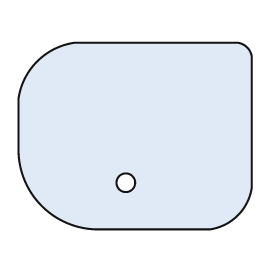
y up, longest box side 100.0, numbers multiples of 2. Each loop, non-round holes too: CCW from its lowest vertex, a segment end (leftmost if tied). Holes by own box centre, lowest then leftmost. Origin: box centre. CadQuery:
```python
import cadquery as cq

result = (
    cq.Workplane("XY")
    .moveTo(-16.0, -40.0)
    .lineTo(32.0, -40.0)
    .threePointArc((44.0, -34.0), (50.0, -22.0))
    .lineTo(50.0, 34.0)
    .threePointArc((48.0, 38.0), (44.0, 40.0))
    .lineTo(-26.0, 40.0)
    .threePointArc((-42.0, 32.0), (-50.0, 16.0))
    .lineTo(-50.0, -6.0)
    .threePointArc((-40.0, -30.0), (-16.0, -40.0))
    .close()
    .moveTo(-4.0, -20.0)
    .circle(4.0)
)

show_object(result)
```